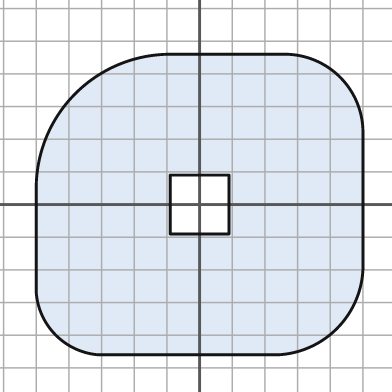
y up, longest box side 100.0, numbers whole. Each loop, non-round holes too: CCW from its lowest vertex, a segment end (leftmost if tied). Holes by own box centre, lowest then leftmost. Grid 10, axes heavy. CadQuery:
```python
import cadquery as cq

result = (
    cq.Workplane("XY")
    .moveTo(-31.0, -46.0)
    .lineTo(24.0, -46.0)
    .threePointArc((42.0, -38.0), (50.0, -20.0))
    .lineTo(50.0, 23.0)
    .threePointArc((43.0, 39.0), (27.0, 46.0))
    .lineTo(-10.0, 46.0)
    .threePointArc((-38.0, 34.0), (-50.0, 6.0))
    .lineTo(-50.0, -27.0)
    .threePointArc((-44.0, -40.0), (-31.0, -46.0))
    .close()
    .moveTo(-9.0, -9.0)
    .lineTo(9.0, -9.0)
    .lineTo(9.0, 9.0)
    .lineTo(-9.0, 9.0)
    .close()
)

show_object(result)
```